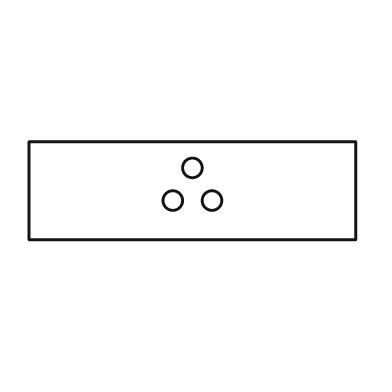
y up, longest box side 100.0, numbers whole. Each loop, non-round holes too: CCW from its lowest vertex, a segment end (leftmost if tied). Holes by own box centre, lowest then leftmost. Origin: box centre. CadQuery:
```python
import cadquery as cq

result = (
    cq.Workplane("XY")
    .moveTo(-50.0, -15.0)
    .lineTo(50.0, -15.0)
    .lineTo(50.0, 15.0)
    .lineTo(-50.0, 15.0)
    .close()
    .moveTo(-6.0, -3.0)
    .circle(3.0)
    .moveTo(6.0, -3.0)
    .circle(3.0)
    .moveTo(0.0, 7.0)
    .circle(3.0)
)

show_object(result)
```